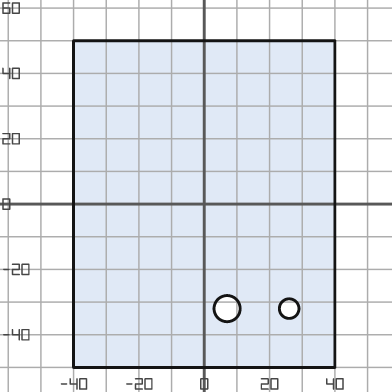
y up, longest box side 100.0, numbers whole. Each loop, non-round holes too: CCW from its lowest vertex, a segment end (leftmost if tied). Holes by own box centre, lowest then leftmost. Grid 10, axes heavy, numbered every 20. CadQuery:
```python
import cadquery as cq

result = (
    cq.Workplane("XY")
    .moveTo(-40.0, -50.0)
    .lineTo(40.0, -50.0)
    .lineTo(40.0, 50.0)
    .lineTo(-40.0, 50.0)
    .close()
    .moveTo(7.0, -32.0)
    .circle(4.0)
    .moveTo(26.0, -32.0)
    .circle(3.0)
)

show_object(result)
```